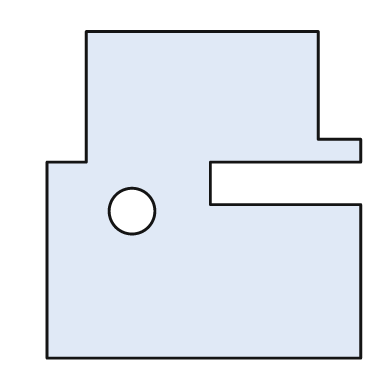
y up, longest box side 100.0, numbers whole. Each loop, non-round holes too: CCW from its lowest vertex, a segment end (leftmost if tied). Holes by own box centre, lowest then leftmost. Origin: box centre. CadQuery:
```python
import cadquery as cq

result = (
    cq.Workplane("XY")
    .moveTo(-48.0, -50.0)
    .lineTo(48.0, -50.0)
    .lineTo(48.0, -3.0)
    .lineTo(2.0, -3.0)
    .lineTo(2.0, 10.0)
    .lineTo(48.0, 10.0)
    .lineTo(48.0, 17.0)
    .lineTo(35.0, 17.0)
    .lineTo(35.0, 50.0)
    .lineTo(-36.0, 50.0)
    .lineTo(-36.0, 10.0)
    .lineTo(-48.0, 10.0)
    .close()
    .moveTo(-22.0, -5.0)
    .circle(7.0)
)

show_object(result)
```